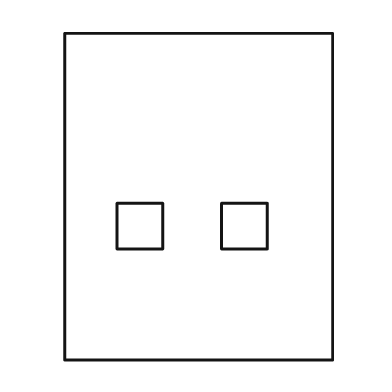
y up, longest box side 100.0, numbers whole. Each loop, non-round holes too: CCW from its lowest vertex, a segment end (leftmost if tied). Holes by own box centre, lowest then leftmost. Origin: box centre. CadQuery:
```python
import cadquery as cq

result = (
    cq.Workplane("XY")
    .moveTo(-41.0, -50.0)
    .lineTo(41.0, -50.0)
    .lineTo(41.0, 50.0)
    .lineTo(-41.0, 50.0)
    .close()
    .moveTo(-25.0, -16.0)
    .lineTo(-11.0, -16.0)
    .lineTo(-11.0, -2.0)
    .lineTo(-25.0, -2.0)
    .close()
    .moveTo(7.0, -16.0)
    .lineTo(21.0, -16.0)
    .lineTo(21.0, -2.0)
    .lineTo(7.0, -2.0)
    .close()
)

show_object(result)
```